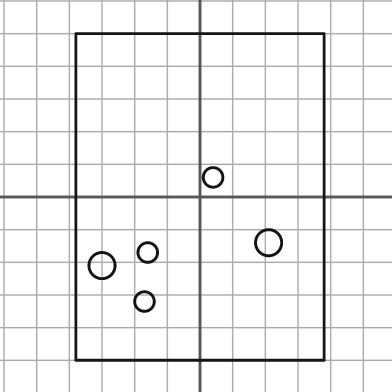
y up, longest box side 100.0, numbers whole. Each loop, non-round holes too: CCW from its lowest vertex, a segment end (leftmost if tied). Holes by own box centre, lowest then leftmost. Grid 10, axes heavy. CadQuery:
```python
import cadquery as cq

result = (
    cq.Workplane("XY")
    .moveTo(-38.0, -50.0)
    .lineTo(38.0, -50.0)
    .lineTo(38.0, 50.0)
    .lineTo(-38.0, 50.0)
    .close()
    .moveTo(-17.0, -32.0)
    .circle(3.0)
    .moveTo(-30.0, -21.0)
    .circle(4.0)
    .moveTo(-16.0, -17.0)
    .circle(3.0)
    .moveTo(21.0, -14.0)
    .circle(4.0)
    .moveTo(4.0, 6.0)
    .circle(3.0)
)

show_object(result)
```